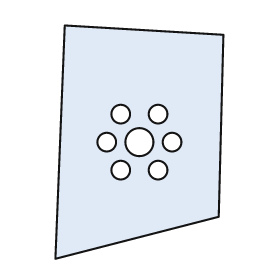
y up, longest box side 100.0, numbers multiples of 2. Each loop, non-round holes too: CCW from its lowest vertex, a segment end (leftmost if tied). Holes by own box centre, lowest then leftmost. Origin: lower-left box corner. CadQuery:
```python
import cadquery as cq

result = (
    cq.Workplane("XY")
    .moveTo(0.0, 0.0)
    .lineTo(70.0, 18.0)
    .lineTo(72.0, 96.0)
    .lineTo(4.0, 100.0)
    .close()
    .moveTo(28.0, 38.0)
    .circle(4.0)
    .moveTo(44.0, 38.0)
    .circle(4.0)
    .moveTo(22.0, 50.0)
    .circle(4.0)
    .moveTo(36.0, 50.0)
    .circle(6.0)
    .moveTo(50.0, 50.0)
    .circle(4.0)
    .moveTo(28.0, 62.0)
    .circle(4.0)
    .moveTo(44.0, 62.0)
    .circle(4.0)
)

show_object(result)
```